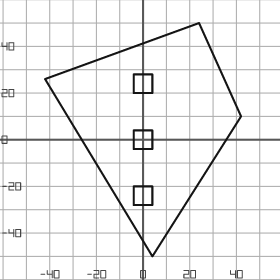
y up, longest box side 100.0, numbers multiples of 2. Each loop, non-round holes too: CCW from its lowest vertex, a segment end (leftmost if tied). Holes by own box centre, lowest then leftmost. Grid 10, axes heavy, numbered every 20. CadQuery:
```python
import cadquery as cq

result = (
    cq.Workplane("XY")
    .moveTo(4.0, -50.0)
    .lineTo(42.0, 10.0)
    .lineTo(24.0, 50.0)
    .lineTo(-42.0, 26.0)
    .close()
    .moveTo(-4.0, -28.0)
    .lineTo(4.0, -28.0)
    .lineTo(4.0, -20.0)
    .lineTo(-4.0, -20.0)
    .close()
    .moveTo(-4.0, -4.0)
    .lineTo(4.0, -4.0)
    .lineTo(4.0, 4.0)
    .lineTo(-4.0, 4.0)
    .close()
    .moveTo(-4.0, 20.0)
    .lineTo(4.0, 20.0)
    .lineTo(4.0, 28.0)
    .lineTo(-4.0, 28.0)
    .close()
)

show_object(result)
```